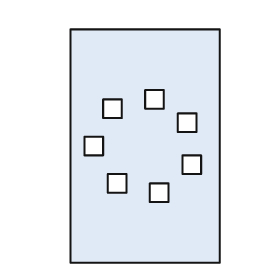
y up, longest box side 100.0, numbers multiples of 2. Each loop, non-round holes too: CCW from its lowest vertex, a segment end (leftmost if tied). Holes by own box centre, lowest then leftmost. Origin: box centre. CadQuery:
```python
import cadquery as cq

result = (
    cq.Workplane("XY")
    .moveTo(-32.0, -50.0)
    .lineTo(32.0, -50.0)
    .lineTo(32.0, 50.0)
    .lineTo(-32.0, 50.0)
    .close()
    .moveTo(2.0, -24.0)
    .lineTo(10.0, -24.0)
    .lineTo(10.0, -16.0)
    .lineTo(2.0, -16.0)
    .close()
    .moveTo(-16.0, -20.0)
    .lineTo(-8.0, -20.0)
    .lineTo(-8.0, -12.0)
    .lineTo(-16.0, -12.0)
    .close()
    .moveTo(16.0, -12.0)
    .lineTo(24.0, -12.0)
    .lineTo(24.0, -4.0)
    .lineTo(16.0, -4.0)
    .close()
    .moveTo(-26.0, -4.0)
    .lineTo(-18.0, -4.0)
    .lineTo(-18.0, 4.0)
    .lineTo(-26.0, 4.0)
    .close()
    .moveTo(14.0, 6.0)
    .lineTo(22.0, 6.0)
    .lineTo(22.0, 14.0)
    .lineTo(14.0, 14.0)
    .close()
    .moveTo(-18.0, 12.0)
    .lineTo(-10.0, 12.0)
    .lineTo(-10.0, 20.0)
    .lineTo(-18.0, 20.0)
    .close()
    .moveTo(0.0, 16.0)
    .lineTo(8.0, 16.0)
    .lineTo(8.0, 24.0)
    .lineTo(0.0, 24.0)
    .close()
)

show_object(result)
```